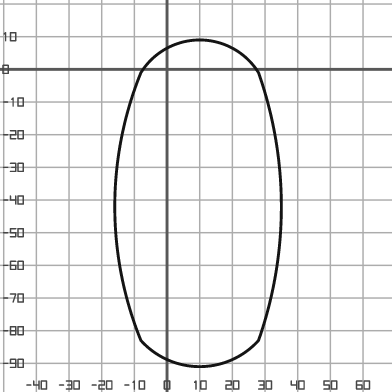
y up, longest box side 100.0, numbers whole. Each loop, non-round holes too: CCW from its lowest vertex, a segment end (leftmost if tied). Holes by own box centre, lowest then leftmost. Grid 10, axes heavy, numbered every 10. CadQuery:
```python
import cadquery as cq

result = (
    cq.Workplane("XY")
    .moveTo(-8.0, -83.0)
    .threePointArc((10.0, -91.0), (28.0, -83.0))
    .threePointArc((35.0, -42.0), (28.0, -1.0))
    .threePointArc((10.0, 9.0), (-8.0, -1.0))
    .threePointArc((-16.0, -42.0), (-8.0, -83.0))
    .close()
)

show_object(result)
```